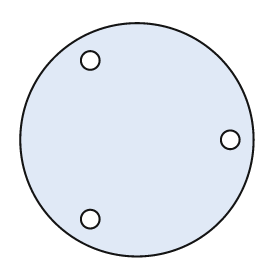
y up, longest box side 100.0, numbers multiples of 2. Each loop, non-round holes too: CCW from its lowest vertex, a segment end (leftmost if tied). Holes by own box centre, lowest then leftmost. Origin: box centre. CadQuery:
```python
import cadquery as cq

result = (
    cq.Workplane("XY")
    .moveTo(0.0, 0.0)
    .circle(50.0)
    .moveTo(-20.0, -34.0)
    .circle(4.0)
    .moveTo(40.0, 0.0)
    .circle(4.0)
    .moveTo(-20.0, 34.0)
    .circle(4.0)
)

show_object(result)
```